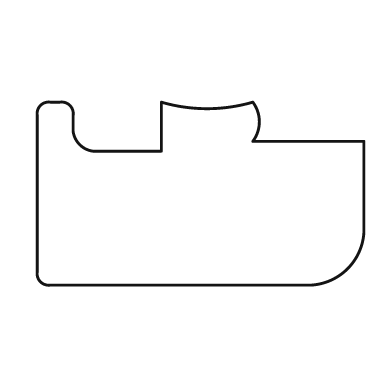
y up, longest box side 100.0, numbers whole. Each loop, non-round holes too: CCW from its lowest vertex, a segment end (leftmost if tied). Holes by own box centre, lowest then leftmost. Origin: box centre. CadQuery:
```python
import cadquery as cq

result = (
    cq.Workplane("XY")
    .moveTo(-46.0, -28.0)
    .lineTo(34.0, -28.0)
    .threePointArc((45.0, -23.0), (50.0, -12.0))
    .lineTo(50.0, 16.0)
    .lineTo(16.0, 16.0)
    .threePointArc((18.0, 22.0), (16.0, 28.0))
    .threePointArc((2.0, 26.0), (-12.0, 28.0))
    .lineTo(-12.0, 13.0)
    .lineTo(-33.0, 13.0)
    .threePointArc((-37.0, 15.0), (-39.0, 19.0))
    .lineTo(-39.0, 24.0)
    .threePointArc((-40.0, 27.0), (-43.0, 28.0))
    .lineTo(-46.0, 28.0)
    .threePointArc((-49.0, 27.0), (-50.0, 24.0))
    .lineTo(-50.0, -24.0)
    .threePointArc((-49.0, -27.0), (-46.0, -28.0))
    .close()
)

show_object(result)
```